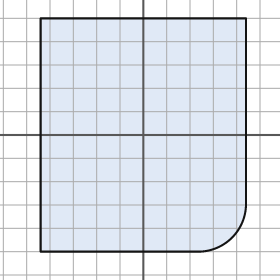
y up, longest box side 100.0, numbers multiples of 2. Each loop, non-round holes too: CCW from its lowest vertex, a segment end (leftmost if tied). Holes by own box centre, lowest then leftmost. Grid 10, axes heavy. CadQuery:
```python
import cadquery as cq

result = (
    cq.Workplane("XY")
    .moveTo(-44.0, -50.0)
    .lineTo(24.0, -50.0)
    .threePointArc((38.0, -44.0), (44.0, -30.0))
    .lineTo(44.0, 50.0)
    .lineTo(-44.0, 50.0)
    .close()
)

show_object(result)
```